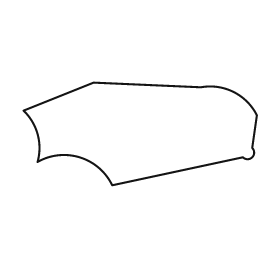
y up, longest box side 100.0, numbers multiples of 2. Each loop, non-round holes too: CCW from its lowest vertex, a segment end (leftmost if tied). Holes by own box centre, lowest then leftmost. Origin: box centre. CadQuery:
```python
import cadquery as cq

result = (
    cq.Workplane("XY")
    .moveTo(-12.0, -22.0)
    .lineTo(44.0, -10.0)
    .threePointArc((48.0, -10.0), (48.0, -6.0))
    .lineTo(50.0, 8.0)
    .threePointArc((40.0, 18.0), (26.0, 20.0))
    .lineTo(-20.0, 22.0)
    .lineTo(-50.0, 10.0)
    .threePointArc((-44.0, 0.0), (-44.0, -12.0))
    .threePointArc((-26.0, -10.0), (-12.0, -22.0))
    .close()
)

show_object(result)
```